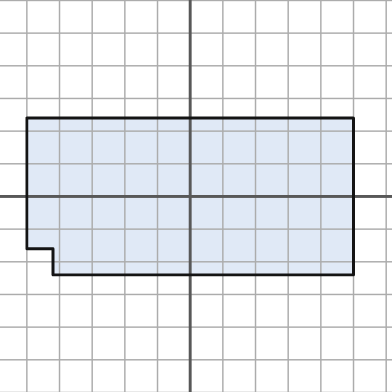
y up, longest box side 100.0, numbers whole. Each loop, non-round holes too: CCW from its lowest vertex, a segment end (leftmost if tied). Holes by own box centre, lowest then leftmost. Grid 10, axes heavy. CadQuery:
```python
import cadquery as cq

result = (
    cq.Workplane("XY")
    .moveTo(-42.0, -24.0)
    .lineTo(50.0, -24.0)
    .lineTo(50.0, 24.0)
    .lineTo(-50.0, 24.0)
    .lineTo(-50.0, -16.0)
    .lineTo(-42.0, -16.0)
    .close()
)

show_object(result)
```